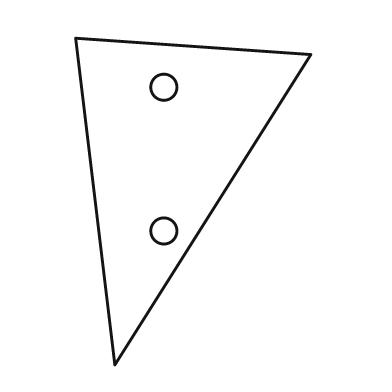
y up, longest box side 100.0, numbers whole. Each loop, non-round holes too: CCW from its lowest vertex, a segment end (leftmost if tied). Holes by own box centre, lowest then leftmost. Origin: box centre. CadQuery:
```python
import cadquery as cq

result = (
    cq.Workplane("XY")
    .moveTo(-24.0, -50.0)
    .lineTo(36.0, 45.0)
    .lineTo(-36.0, 50.0)
    .close()
    .moveTo(-9.0, -9.0)
    .circle(4.0)
    .moveTo(-9.0, 35.0)
    .circle(4.0)
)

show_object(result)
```